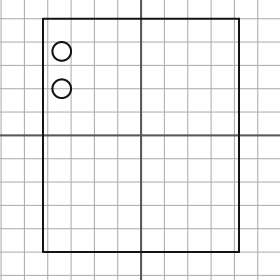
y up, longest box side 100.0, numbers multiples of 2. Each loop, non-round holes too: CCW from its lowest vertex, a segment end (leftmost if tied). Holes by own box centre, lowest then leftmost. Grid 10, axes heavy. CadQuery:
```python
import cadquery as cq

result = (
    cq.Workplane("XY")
    .moveTo(-42.0, -50.0)
    .lineTo(42.0, -50.0)
    .lineTo(42.0, 50.0)
    .lineTo(-42.0, 50.0)
    .close()
    .moveTo(-34.0, 20.0)
    .circle(4.0)
    .moveTo(-34.0, 36.0)
    .circle(4.0)
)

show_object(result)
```